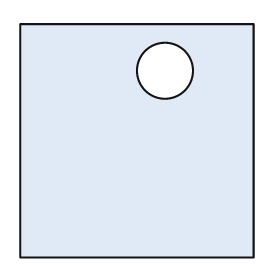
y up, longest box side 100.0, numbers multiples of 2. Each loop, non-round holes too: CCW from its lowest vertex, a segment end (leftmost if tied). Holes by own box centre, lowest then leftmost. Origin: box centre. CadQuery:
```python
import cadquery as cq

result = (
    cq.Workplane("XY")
    .moveTo(-50.0, -50.0)
    .lineTo(50.0, -50.0)
    .lineTo(50.0, 50.0)
    .lineTo(-50.0, 50.0)
    .close()
    .moveTo(12.0, 30.0)
    .circle(12.0)
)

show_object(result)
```